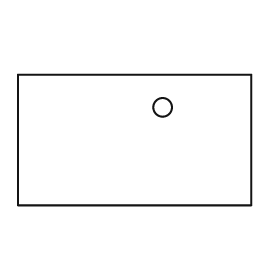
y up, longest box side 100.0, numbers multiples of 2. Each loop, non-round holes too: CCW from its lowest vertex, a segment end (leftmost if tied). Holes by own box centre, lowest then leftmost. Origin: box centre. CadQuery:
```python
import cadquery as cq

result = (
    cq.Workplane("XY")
    .moveTo(-50.0, -28.0)
    .lineTo(50.0, -28.0)
    .lineTo(50.0, 28.0)
    .lineTo(-50.0, 28.0)
    .close()
    .moveTo(12.0, 14.0)
    .circle(4.0)
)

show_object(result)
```